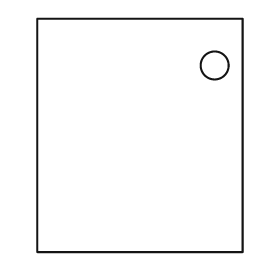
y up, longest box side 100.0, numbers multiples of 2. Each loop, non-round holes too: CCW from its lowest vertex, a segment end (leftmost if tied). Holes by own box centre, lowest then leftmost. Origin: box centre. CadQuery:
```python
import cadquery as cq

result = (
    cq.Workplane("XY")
    .moveTo(-44.0, -50.0)
    .lineTo(44.0, -50.0)
    .lineTo(44.0, 50.0)
    .lineTo(-44.0, 50.0)
    .close()
    .moveTo(32.0, 30.0)
    .circle(6.0)
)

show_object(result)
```